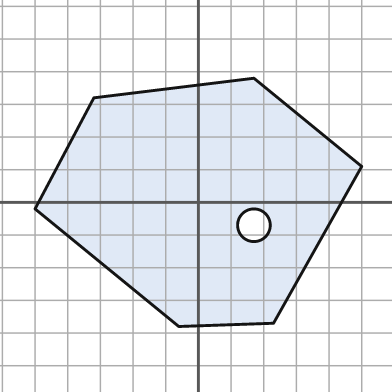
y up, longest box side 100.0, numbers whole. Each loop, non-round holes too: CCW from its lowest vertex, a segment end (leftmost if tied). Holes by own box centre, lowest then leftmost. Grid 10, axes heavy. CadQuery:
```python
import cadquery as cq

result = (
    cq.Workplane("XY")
    .moveTo(-6.0, -38.0)
    .lineTo(23.0, -37.0)
    .lineTo(50.0, 11.0)
    .lineTo(17.0, 38.0)
    .lineTo(-32.0, 32.0)
    .lineTo(-50.0, -2.0)
    .close()
    .moveTo(17.0, -7.0)
    .circle(5.0)
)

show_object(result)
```